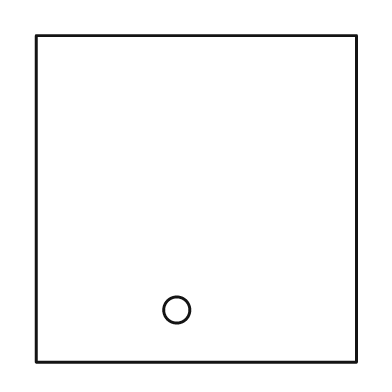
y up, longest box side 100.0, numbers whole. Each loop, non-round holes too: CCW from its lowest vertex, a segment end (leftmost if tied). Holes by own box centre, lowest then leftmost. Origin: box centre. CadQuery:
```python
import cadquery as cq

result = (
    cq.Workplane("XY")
    .moveTo(-49.0, -50.0)
    .lineTo(49.0, -50.0)
    .lineTo(49.0, 50.0)
    .lineTo(-49.0, 50.0)
    .close()
    .moveTo(-6.0, -34.0)
    .circle(4.0)
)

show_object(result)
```